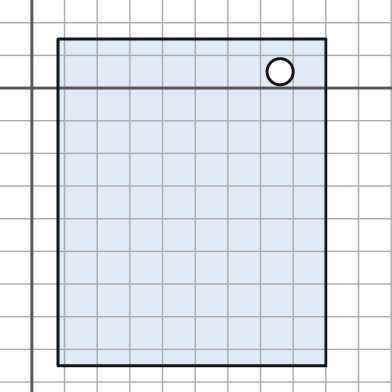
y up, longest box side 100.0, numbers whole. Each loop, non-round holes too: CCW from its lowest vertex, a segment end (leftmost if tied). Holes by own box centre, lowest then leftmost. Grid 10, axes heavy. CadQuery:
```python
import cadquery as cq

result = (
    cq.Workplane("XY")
    .moveTo(8.0, -85.0)
    .lineTo(90.0, -85.0)
    .lineTo(90.0, 15.0)
    .lineTo(8.0, 15.0)
    .close()
    .moveTo(76.0, 5.0)
    .circle(4.0)
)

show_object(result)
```